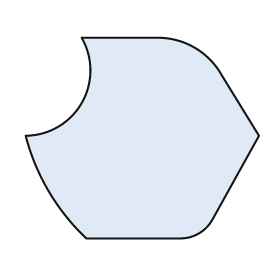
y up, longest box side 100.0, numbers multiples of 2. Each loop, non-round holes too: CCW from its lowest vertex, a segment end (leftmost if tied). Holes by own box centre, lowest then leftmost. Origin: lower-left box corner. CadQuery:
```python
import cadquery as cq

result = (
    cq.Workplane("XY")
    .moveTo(26.0, 0.0)
    .lineTo(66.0, 0.0)
    .threePointArc((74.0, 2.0), (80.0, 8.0))
    .lineTo(100.0, 44.0)
    .lineTo(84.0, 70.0)
    .threePointArc((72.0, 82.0), (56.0, 86.0))
    .lineTo(24.0, 86.0)
    .threePointArc((24.0, 58.0), (0.0, 44.0))
    .threePointArc((10.0, 20.0), (26.0, 0.0))
    .close()
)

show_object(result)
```